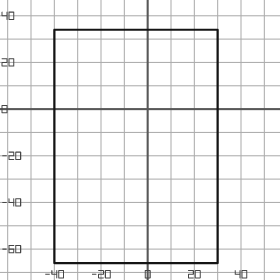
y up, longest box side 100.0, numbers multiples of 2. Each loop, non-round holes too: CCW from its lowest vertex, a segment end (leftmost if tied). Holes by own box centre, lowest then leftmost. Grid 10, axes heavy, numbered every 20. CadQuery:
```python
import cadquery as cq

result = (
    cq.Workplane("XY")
    .moveTo(-40.0, -66.0)
    .lineTo(30.0, -66.0)
    .lineTo(30.0, 34.0)
    .lineTo(-40.0, 34.0)
    .close()
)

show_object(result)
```